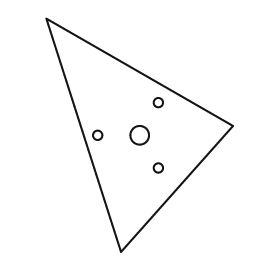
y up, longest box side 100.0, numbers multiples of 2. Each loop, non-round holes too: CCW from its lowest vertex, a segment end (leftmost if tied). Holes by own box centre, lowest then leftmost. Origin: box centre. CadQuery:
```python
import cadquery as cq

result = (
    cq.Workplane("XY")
    .moveTo(-8.0, -50.0)
    .lineTo(40.0, 4.0)
    .lineTo(-40.0, 50.0)
    .close()
    .moveTo(8.0, -14.0)
    .circle(2.0)
    .moveTo(-18.0, 0.0)
    .circle(2.0)
    .moveTo(0.0, 0.0)
    .circle(4.0)
    .moveTo(8.0, 14.0)
    .circle(2.0)
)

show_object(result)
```